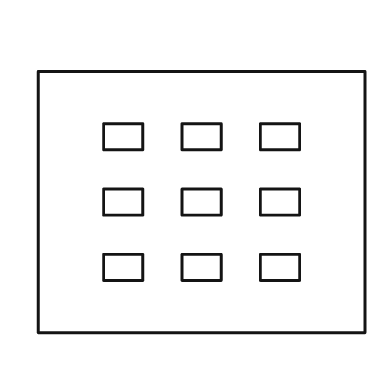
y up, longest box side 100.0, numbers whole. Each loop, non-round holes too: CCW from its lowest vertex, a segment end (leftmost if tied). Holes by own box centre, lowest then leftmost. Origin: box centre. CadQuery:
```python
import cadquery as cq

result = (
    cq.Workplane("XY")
    .moveTo(-50.0, -40.0)
    .lineTo(50.0, -40.0)
    .lineTo(50.0, 40.0)
    .lineTo(-50.0, 40.0)
    .close()
    .moveTo(-30.0, -24.0)
    .lineTo(-18.0, -24.0)
    .lineTo(-18.0, -16.0)
    .lineTo(-30.0, -16.0)
    .close()
    .moveTo(-6.0, -24.0)
    .lineTo(6.0, -24.0)
    .lineTo(6.0, -16.0)
    .lineTo(-6.0, -16.0)
    .close()
    .moveTo(18.0, -24.0)
    .lineTo(30.0, -24.0)
    .lineTo(30.0, -16.0)
    .lineTo(18.0, -16.0)
    .close()
    .moveTo(-30.0, -4.0)
    .lineTo(-18.0, -4.0)
    .lineTo(-18.0, 4.0)
    .lineTo(-30.0, 4.0)
    .close()
    .moveTo(-6.0, -4.0)
    .lineTo(6.0, -4.0)
    .lineTo(6.0, 4.0)
    .lineTo(-6.0, 4.0)
    .close()
    .moveTo(18.0, -4.0)
    .lineTo(30.0, -4.0)
    .lineTo(30.0, 4.0)
    .lineTo(18.0, 4.0)
    .close()
    .moveTo(-30.0, 16.0)
    .lineTo(-18.0, 16.0)
    .lineTo(-18.0, 24.0)
    .lineTo(-30.0, 24.0)
    .close()
    .moveTo(-6.0, 16.0)
    .lineTo(6.0, 16.0)
    .lineTo(6.0, 24.0)
    .lineTo(-6.0, 24.0)
    .close()
    .moveTo(18.0, 16.0)
    .lineTo(30.0, 16.0)
    .lineTo(30.0, 24.0)
    .lineTo(18.0, 24.0)
    .close()
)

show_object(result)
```